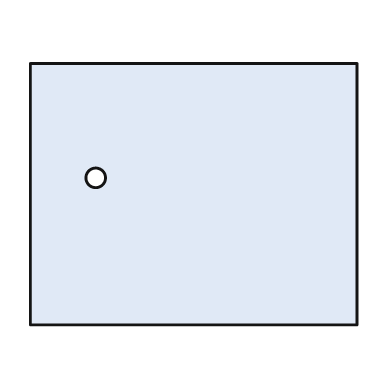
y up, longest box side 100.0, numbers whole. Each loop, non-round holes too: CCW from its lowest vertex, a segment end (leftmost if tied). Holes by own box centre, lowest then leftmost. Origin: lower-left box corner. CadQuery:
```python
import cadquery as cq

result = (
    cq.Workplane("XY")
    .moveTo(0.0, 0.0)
    .lineTo(100.0, 0.0)
    .lineTo(100.0, 80.0)
    .lineTo(0.0, 80.0)
    .close()
    .moveTo(20.0, 45.0)
    .circle(3.0)
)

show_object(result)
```